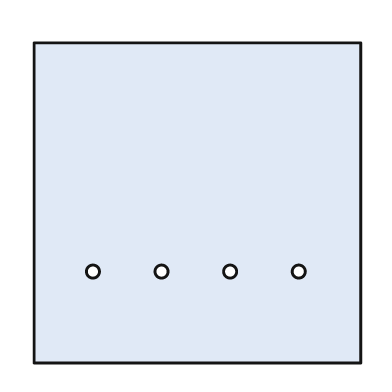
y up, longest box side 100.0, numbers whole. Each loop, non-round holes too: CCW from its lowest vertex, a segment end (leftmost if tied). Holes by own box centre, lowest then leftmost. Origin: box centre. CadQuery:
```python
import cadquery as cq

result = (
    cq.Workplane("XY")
    .moveTo(-50.0, -49.0)
    .lineTo(50.0, -49.0)
    .lineTo(50.0, 49.0)
    .lineTo(-50.0, 49.0)
    .close()
    .moveTo(-32.0, -21.0)
    .circle(2.0)
    .moveTo(-11.0, -21.0)
    .circle(2.0)
    .moveTo(10.0, -21.0)
    .circle(2.0)
    .moveTo(31.0, -21.0)
    .circle(2.0)
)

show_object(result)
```